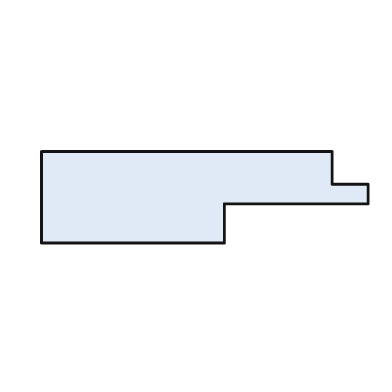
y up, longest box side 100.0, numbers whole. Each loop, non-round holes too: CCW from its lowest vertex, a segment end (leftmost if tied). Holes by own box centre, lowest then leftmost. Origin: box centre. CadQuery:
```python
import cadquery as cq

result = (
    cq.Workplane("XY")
    .moveTo(-50.0, -14.0)
    .lineTo(6.0, -14.0)
    .lineTo(6.0, -2.0)
    .lineTo(50.0, -2.0)
    .lineTo(50.0, 4.0)
    .lineTo(39.0, 4.0)
    .lineTo(39.0, 14.0)
    .lineTo(-50.0, 14.0)
    .close()
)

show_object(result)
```